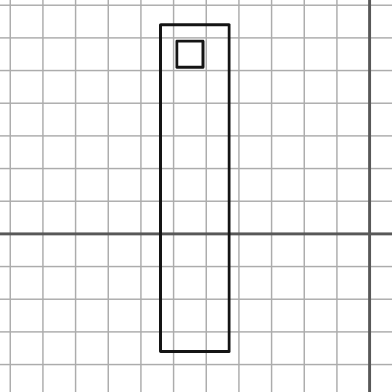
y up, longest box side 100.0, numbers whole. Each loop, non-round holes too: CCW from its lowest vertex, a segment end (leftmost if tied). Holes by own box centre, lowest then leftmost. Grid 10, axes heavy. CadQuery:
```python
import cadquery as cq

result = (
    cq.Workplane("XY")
    .moveTo(-64.0, -36.0)
    .lineTo(-43.0, -36.0)
    .lineTo(-43.0, 64.0)
    .lineTo(-64.0, 64.0)
    .close()
    .moveTo(-59.0, 51.0)
    .lineTo(-51.0, 51.0)
    .lineTo(-51.0, 59.0)
    .lineTo(-59.0, 59.0)
    .close()
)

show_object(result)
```